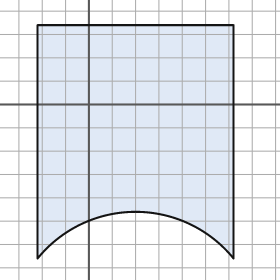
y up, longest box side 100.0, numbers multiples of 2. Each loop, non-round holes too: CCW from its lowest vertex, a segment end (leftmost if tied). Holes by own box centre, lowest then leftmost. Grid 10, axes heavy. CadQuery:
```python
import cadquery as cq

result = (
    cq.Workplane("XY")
    .moveTo(-22.0, -66.0)
    .threePointArc((20.0, -46.0), (62.0, -66.0))
    .lineTo(62.0, 34.0)
    .lineTo(-22.0, 34.0)
    .close()
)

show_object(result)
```